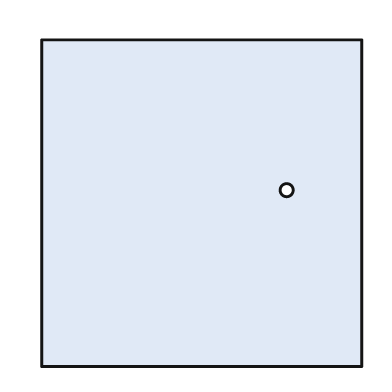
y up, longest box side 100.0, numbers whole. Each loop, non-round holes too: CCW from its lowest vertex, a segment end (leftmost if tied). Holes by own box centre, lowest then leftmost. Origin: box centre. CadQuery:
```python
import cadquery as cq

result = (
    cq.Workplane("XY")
    .moveTo(-49.0, -50.0)
    .lineTo(49.0, -50.0)
    .lineTo(49.0, 50.0)
    .lineTo(-49.0, 50.0)
    .close()
    .moveTo(26.0, 4.0)
    .circle(2.0)
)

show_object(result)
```